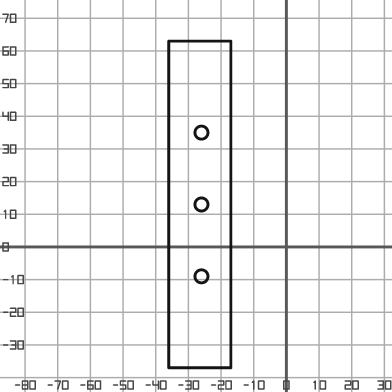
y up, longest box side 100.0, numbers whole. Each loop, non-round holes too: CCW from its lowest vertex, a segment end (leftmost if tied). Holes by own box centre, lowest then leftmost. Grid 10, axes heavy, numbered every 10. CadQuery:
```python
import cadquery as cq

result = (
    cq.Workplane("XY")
    .moveTo(-36.0, -37.0)
    .lineTo(-17.0, -37.0)
    .lineTo(-17.0, 63.0)
    .lineTo(-36.0, 63.0)
    .close()
    .moveTo(-26.0, -9.0)
    .circle(2.0)
    .moveTo(-26.0, 13.0)
    .circle(2.0)
    .moveTo(-26.0, 35.0)
    .circle(2.0)
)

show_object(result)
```